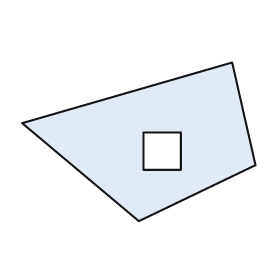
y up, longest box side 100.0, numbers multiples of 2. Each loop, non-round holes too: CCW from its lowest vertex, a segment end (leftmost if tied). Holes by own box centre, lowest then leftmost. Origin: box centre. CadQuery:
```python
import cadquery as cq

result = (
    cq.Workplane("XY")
    .moveTo(0.0, -34.0)
    .lineTo(50.0, -10.0)
    .lineTo(40.0, 34.0)
    .lineTo(-50.0, 8.0)
    .close()
    .moveTo(2.0, -12.0)
    .lineTo(18.0, -12.0)
    .lineTo(18.0, 4.0)
    .lineTo(2.0, 4.0)
    .close()
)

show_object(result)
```